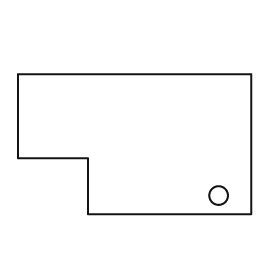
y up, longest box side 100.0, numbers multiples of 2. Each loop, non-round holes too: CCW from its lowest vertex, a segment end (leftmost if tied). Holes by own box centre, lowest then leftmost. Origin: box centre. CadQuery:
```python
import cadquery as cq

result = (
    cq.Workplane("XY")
    .moveTo(-20.0, -30.0)
    .lineTo(50.0, -30.0)
    .lineTo(50.0, 30.0)
    .lineTo(-50.0, 30.0)
    .lineTo(-50.0, -6.0)
    .lineTo(-20.0, -6.0)
    .close()
    .moveTo(36.0, -22.0)
    .circle(4.0)
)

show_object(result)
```